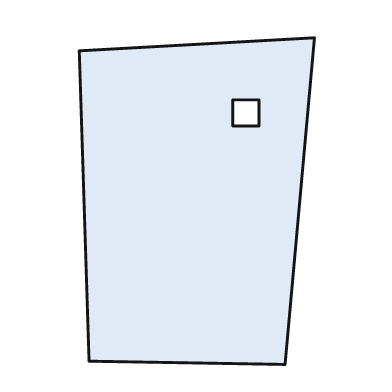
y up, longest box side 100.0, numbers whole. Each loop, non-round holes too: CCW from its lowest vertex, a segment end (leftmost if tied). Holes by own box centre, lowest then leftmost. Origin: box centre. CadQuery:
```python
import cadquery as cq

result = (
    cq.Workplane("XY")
    .moveTo(27.0, -50.0)
    .lineTo(36.0, 50.0)
    .lineTo(-36.0, 46.0)
    .lineTo(-33.0, -49.0)
    .close()
    .moveTo(11.0, 23.0)
    .lineTo(19.0, 23.0)
    .lineTo(19.0, 31.0)
    .lineTo(11.0, 31.0)
    .close()
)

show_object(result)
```